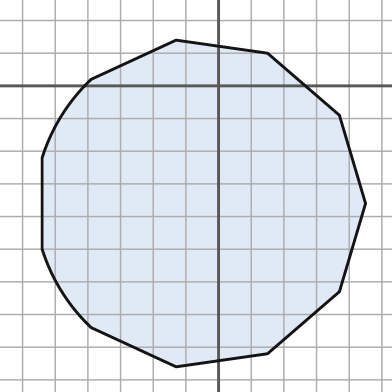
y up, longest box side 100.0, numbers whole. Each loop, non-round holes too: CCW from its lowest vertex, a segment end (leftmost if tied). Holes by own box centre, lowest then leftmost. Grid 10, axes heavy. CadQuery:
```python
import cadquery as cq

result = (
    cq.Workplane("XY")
    .moveTo(-13.0, -86.0)
    .lineTo(15.0, -82.0)
    .lineTo(37.0, -63.0)
    .lineTo(45.0, -36.0)
    .lineTo(37.0, -9.0)
    .lineTo(15.0, 10.0)
    .lineTo(-13.0, 14.0)
    .lineTo(-39.0, 2.0)
    .threePointArc((-48.0, -9.0), (-54.0, -22.0))
    .lineTo(-54.0, -50.0)
    .threePointArc((-48.0, -63.0), (-39.0, -74.0))
    .close()
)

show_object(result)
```